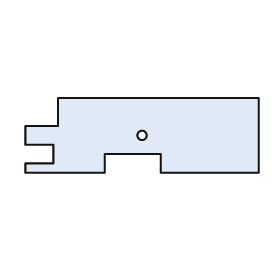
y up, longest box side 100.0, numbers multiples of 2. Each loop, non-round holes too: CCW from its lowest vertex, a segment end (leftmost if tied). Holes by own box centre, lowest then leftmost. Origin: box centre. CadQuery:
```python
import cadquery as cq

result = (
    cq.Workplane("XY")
    .moveTo(-50.0, -16.0)
    .lineTo(-16.0, -16.0)
    .lineTo(-16.0, -8.0)
    .lineTo(8.0, -8.0)
    .lineTo(8.0, -16.0)
    .lineTo(50.0, -16.0)
    .lineTo(50.0, 16.0)
    .lineTo(-36.0, 16.0)
    .lineTo(-36.0, 4.0)
    .lineTo(-50.0, 4.0)
    .lineTo(-50.0, -4.0)
    .lineTo(-38.0, -4.0)
    .lineTo(-38.0, -12.0)
    .lineTo(-50.0, -12.0)
    .close()
    .moveTo(0.0, 0.0)
    .circle(2.0)
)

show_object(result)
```